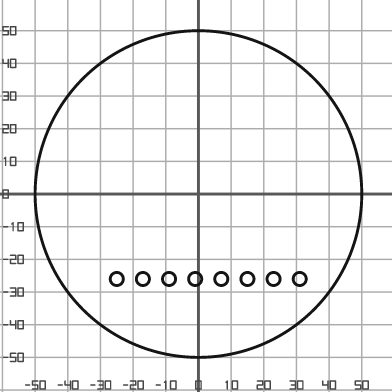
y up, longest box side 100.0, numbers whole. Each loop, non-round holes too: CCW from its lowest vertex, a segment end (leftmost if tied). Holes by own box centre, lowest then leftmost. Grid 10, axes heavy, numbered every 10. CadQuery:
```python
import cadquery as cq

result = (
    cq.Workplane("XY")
    .moveTo(0.0, 0.0)
    .circle(50.0)
    .moveTo(-25.0, -26.0)
    .circle(2.0)
    .moveTo(-17.0, -26.0)
    .circle(2.0)
    .moveTo(-9.0, -26.0)
    .circle(2.0)
    .moveTo(-1.0, -26.0)
    .circle(2.0)
    .moveTo(7.0, -26.0)
    .circle(2.0)
    .moveTo(15.0, -26.0)
    .circle(2.0)
    .moveTo(23.0, -26.0)
    .circle(2.0)
    .moveTo(31.0, -26.0)
    .circle(2.0)
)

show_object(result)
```